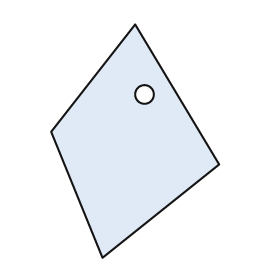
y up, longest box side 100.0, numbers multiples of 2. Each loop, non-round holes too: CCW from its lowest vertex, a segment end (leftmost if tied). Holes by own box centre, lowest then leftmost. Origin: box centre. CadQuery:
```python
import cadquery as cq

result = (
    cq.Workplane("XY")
    .moveTo(-14.0, -50.0)
    .lineTo(36.0, -10.0)
    .lineTo(0.0, 50.0)
    .lineTo(-36.0, 4.0)
    .close()
    .moveTo(4.0, 20.0)
    .circle(4.0)
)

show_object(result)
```